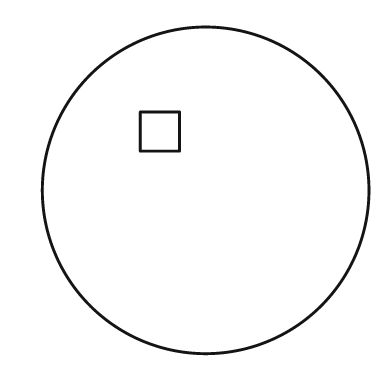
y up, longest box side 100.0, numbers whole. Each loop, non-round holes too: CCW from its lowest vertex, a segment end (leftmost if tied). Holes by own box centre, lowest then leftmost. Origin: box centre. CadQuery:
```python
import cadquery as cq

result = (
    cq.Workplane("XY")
    .moveTo(0.0, 0.0)
    .circle(50.0)
    .moveTo(-20.0, 12.0)
    .lineTo(-8.0, 12.0)
    .lineTo(-8.0, 24.0)
    .lineTo(-20.0, 24.0)
    .close()
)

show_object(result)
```